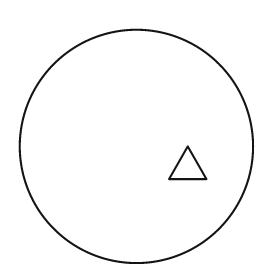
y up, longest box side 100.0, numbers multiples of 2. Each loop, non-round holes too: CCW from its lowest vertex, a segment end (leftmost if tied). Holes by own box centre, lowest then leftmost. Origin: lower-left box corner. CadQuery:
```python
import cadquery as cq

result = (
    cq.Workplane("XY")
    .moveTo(50.0, 50.0)
    .circle(50.0)
    .moveTo(64.0, 36.0)
    .lineTo(80.0, 36.0)
    .lineTo(72.0, 50.0)
    .close()
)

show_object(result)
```